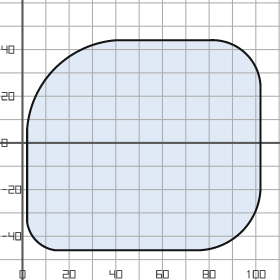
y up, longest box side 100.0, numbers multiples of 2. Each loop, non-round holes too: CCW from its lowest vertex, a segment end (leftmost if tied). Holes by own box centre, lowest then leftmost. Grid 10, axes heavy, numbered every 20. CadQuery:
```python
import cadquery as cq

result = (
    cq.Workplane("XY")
    .moveTo(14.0, -46.0)
    .lineTo(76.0, -46.0)
    .threePointArc((94.0, -38.0), (102.0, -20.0))
    .lineTo(102.0, 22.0)
    .threePointArc((96.0, 38.0), (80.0, 44.0))
    .lineTo(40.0, 44.0)
    .threePointArc((14.0, 32.0), (2.0, 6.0))
    .lineTo(2.0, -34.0)
    .threePointArc((6.0, -42.0), (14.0, -46.0))
    .close()
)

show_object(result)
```